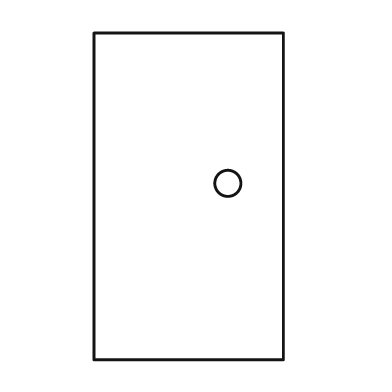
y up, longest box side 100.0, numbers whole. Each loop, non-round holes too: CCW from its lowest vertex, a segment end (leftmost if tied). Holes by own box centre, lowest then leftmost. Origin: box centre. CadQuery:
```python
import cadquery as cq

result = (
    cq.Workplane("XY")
    .moveTo(-29.0, -50.0)
    .lineTo(29.0, -50.0)
    .lineTo(29.0, 50.0)
    .lineTo(-29.0, 50.0)
    .close()
    .moveTo(12.0, 4.0)
    .circle(4.0)
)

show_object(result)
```